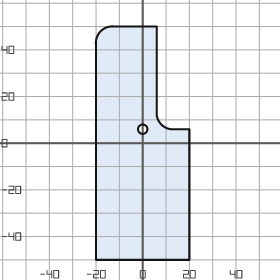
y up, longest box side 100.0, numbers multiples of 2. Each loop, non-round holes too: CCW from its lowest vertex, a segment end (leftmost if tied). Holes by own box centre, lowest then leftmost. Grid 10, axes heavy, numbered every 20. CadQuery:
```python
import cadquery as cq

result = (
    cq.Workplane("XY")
    .moveTo(-20.0, -50.0)
    .lineTo(20.0, -50.0)
    .lineTo(20.0, 6.0)
    .lineTo(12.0, 6.0)
    .threePointArc((8.0, 8.0), (6.0, 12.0))
    .lineTo(6.0, 50.0)
    .lineTo(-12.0, 50.0)
    .threePointArc((-18.0, 48.0), (-20.0, 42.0))
    .close()
    .moveTo(0.0, 6.0)
    .circle(2.0)
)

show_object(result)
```